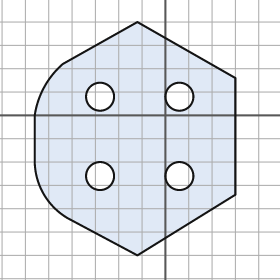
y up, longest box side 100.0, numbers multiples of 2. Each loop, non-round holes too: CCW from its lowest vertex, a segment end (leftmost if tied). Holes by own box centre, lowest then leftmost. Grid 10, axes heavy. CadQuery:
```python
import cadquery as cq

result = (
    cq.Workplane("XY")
    .moveTo(-12.0, -60.0)
    .lineTo(30.0, -34.0)
    .lineTo(30.0, 16.0)
    .lineTo(-12.0, 40.0)
    .lineTo(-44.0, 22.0)
    .threePointArc((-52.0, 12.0), (-56.0, 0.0))
    .lineTo(-56.0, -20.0)
    .threePointArc((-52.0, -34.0), (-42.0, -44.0))
    .close()
    .moveTo(-28.0, -26.0)
    .circle(6.0)
    .moveTo(6.0, -26.0)
    .circle(6.0)
    .moveTo(-28.0, 8.0)
    .circle(6.0)
    .moveTo(6.0, 8.0)
    .circle(6.0)
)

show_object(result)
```